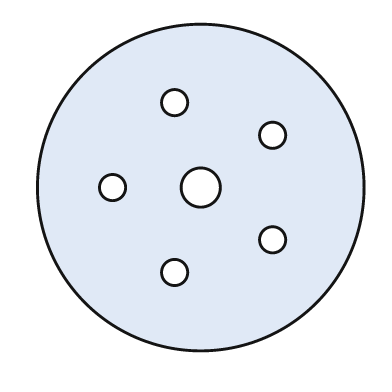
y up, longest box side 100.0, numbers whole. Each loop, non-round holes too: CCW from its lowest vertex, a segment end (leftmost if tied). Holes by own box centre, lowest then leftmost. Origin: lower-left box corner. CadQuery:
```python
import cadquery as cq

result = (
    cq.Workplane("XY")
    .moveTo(50.0, 50.0)
    .circle(50.0)
    .moveTo(42.0, 24.0)
    .circle(4.0)
    .moveTo(72.0, 34.0)
    .circle(4.0)
    .moveTo(23.0, 50.0)
    .circle(4.0)
    .moveTo(50.0, 50.0)
    .circle(6.0)
    .moveTo(72.0, 66.0)
    .circle(4.0)
    .moveTo(42.0, 76.0)
    .circle(4.0)
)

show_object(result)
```